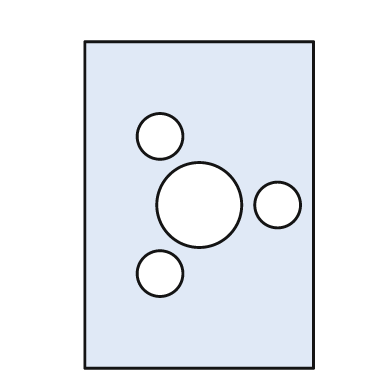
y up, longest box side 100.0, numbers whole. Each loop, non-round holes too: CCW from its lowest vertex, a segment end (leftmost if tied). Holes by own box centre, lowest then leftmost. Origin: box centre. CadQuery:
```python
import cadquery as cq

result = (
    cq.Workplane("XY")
    .moveTo(-35.0, -50.0)
    .lineTo(35.0, -50.0)
    .lineTo(35.0, 50.0)
    .lineTo(-35.0, 50.0)
    .close()
    .moveTo(-12.0, -21.0)
    .circle(7.0)
    .moveTo(0.0, 0.0)
    .circle(13.0)
    .moveTo(24.0, 0.0)
    .circle(7.0)
    .moveTo(-12.0, 21.0)
    .circle(7.0)
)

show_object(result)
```